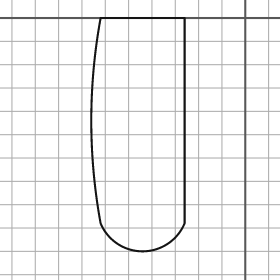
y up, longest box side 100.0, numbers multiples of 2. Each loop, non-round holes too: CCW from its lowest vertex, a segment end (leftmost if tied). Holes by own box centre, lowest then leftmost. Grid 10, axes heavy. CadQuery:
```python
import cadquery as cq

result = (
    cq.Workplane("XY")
    .moveTo(-62.0, -88.0)
    .threePointArc((-44.0, -100.0), (-26.0, -88.0))
    .lineTo(-26.0, 0.0)
    .lineTo(-62.0, 0.0)
    .threePointArc((-66.0, -44.0), (-62.0, -88.0))
    .close()
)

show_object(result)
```